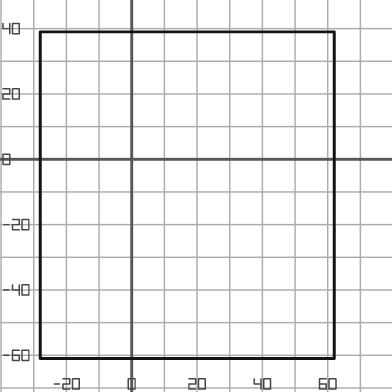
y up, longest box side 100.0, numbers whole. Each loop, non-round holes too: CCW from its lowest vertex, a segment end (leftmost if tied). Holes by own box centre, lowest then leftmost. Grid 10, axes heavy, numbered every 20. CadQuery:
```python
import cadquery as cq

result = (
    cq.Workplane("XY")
    .moveTo(-28.0, -61.0)
    .lineTo(62.0, -61.0)
    .lineTo(62.0, 39.0)
    .lineTo(-28.0, 39.0)
    .close()
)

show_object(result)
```